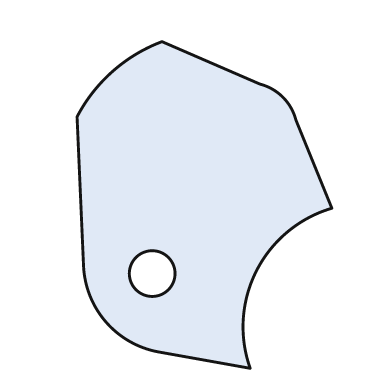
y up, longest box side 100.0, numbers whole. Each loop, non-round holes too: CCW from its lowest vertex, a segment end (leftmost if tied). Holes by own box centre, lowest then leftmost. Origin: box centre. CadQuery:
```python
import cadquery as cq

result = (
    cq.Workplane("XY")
    .moveTo(14.0, -50.0)
    .threePointArc((16.0, -20.0), (39.0, -1.0))
    .lineTo(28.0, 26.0)
    .threePointArc((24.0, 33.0), (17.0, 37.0))
    .lineTo(-13.0, 50.0)
    .threePointArc((-28.0, 41.0), (-39.0, 27.0))
    .lineTo(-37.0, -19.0)
    .threePointArc((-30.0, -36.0), (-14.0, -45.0))
    .close()
    .moveTo(-16.0, -21.0)
    .circle(7.0)
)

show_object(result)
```